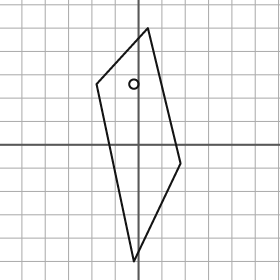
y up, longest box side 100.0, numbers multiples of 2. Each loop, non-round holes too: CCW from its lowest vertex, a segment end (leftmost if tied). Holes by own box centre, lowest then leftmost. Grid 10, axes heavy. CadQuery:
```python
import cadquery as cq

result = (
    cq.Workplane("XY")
    .moveTo(-2.0, -50.0)
    .lineTo(18.0, -8.0)
    .lineTo(4.0, 50.0)
    .lineTo(-18.0, 26.0)
    .close()
    .moveTo(-2.0, 26.0)
    .circle(2.0)
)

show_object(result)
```